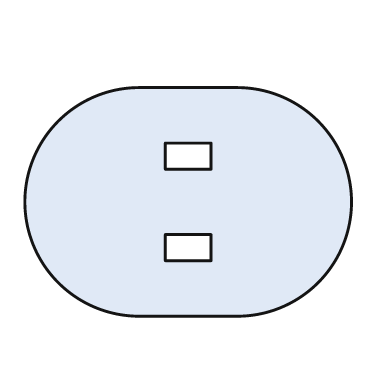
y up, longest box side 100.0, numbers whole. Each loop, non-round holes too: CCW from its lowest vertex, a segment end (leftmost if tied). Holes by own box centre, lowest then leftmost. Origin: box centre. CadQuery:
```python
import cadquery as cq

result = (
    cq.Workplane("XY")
    .moveTo(-15.0, -35.0)
    .lineTo(15.0, -35.0)
    .threePointArc((50.0, 0.0), (15.0, 35.0))
    .lineTo(-15.0, 35.0)
    .threePointArc((-50.0, 0.0), (-15.0, -35.0))
    .close()
    .moveTo(-7.0, -18.0)
    .lineTo(7.0, -18.0)
    .lineTo(7.0, -10.0)
    .lineTo(-7.0, -10.0)
    .close()
    .moveTo(-7.0, 10.0)
    .lineTo(7.0, 10.0)
    .lineTo(7.0, 18.0)
    .lineTo(-7.0, 18.0)
    .close()
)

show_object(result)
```